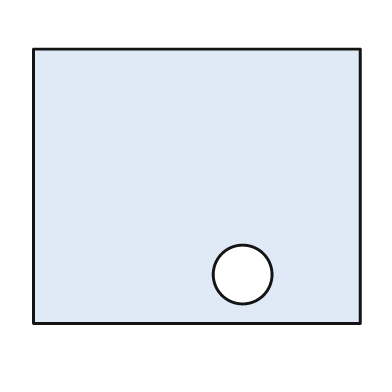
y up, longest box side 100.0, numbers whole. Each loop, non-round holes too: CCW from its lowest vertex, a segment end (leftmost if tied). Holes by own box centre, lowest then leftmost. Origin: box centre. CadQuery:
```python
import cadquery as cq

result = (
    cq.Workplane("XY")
    .moveTo(-50.0, -42.0)
    .lineTo(50.0, -42.0)
    .lineTo(50.0, 42.0)
    .lineTo(-50.0, 42.0)
    .close()
    .moveTo(14.0, -27.0)
    .circle(9.0)
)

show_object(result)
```